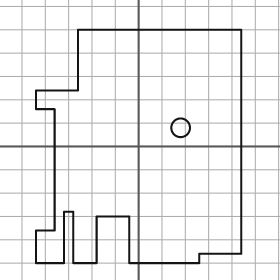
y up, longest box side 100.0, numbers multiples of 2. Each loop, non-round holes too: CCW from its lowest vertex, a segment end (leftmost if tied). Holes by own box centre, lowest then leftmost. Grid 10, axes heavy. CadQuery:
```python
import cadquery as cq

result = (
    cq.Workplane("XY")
    .moveTo(-44.0, -50.0)
    .lineTo(-32.0, -50.0)
    .lineTo(-32.0, -28.0)
    .lineTo(-28.0, -28.0)
    .lineTo(-28.0, -50.0)
    .lineTo(-18.0, -50.0)
    .lineTo(-18.0, -30.0)
    .lineTo(-4.0, -30.0)
    .lineTo(-4.0, -50.0)
    .lineTo(26.0, -50.0)
    .lineTo(26.0, -46.0)
    .lineTo(44.0, -46.0)
    .lineTo(44.0, 50.0)
    .lineTo(-26.0, 50.0)
    .lineTo(-26.0, 24.0)
    .lineTo(-44.0, 24.0)
    .lineTo(-44.0, 16.0)
    .lineTo(-36.0, 16.0)
    .lineTo(-36.0, -36.0)
    .lineTo(-44.0, -36.0)
    .close()
    .moveTo(18.0, 8.0)
    .circle(4.0)
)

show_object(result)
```